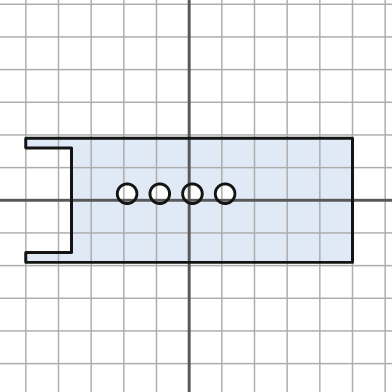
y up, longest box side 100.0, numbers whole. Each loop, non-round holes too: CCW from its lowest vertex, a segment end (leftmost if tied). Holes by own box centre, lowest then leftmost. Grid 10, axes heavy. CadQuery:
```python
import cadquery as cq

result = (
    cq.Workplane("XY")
    .moveTo(-50.0, -19.0)
    .lineTo(50.0, -19.0)
    .lineTo(50.0, 19.0)
    .lineTo(-50.0, 19.0)
    .lineTo(-50.0, 16.0)
    .lineTo(-36.0, 16.0)
    .lineTo(-36.0, -16.0)
    .lineTo(-50.0, -16.0)
    .close()
    .moveTo(-19.0, 2.0)
    .circle(3.0)
    .moveTo(-9.0, 2.0)
    .circle(3.0)
    .moveTo(1.0, 2.0)
    .circle(3.0)
    .moveTo(11.0, 2.0)
    .circle(3.0)
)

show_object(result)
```